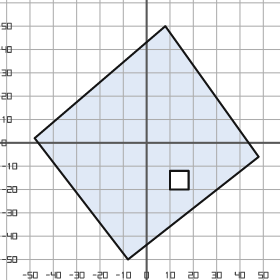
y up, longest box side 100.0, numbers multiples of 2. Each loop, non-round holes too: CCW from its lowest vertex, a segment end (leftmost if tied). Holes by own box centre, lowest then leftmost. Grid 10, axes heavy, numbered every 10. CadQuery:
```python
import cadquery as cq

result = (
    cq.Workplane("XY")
    .moveTo(-8.0, -50.0)
    .lineTo(48.0, -6.0)
    .lineTo(8.0, 50.0)
    .lineTo(-48.0, 2.0)
    .close()
    .moveTo(10.0, -20.0)
    .lineTo(18.0, -20.0)
    .lineTo(18.0, -12.0)
    .lineTo(10.0, -12.0)
    .close()
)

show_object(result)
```